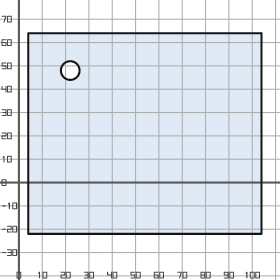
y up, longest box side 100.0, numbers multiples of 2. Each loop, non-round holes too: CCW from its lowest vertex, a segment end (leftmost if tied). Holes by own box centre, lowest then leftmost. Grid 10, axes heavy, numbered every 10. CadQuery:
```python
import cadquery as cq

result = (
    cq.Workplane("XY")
    .moveTo(4.0, -22.0)
    .lineTo(104.0, -22.0)
    .lineTo(104.0, 64.0)
    .lineTo(4.0, 64.0)
    .close()
    .moveTo(22.0, 48.0)
    .circle(4.0)
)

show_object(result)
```